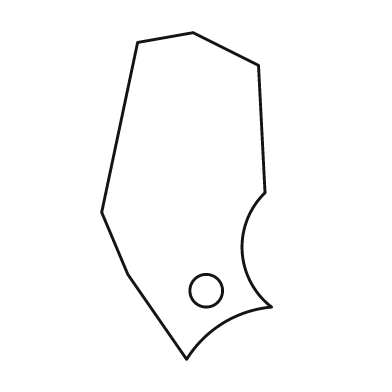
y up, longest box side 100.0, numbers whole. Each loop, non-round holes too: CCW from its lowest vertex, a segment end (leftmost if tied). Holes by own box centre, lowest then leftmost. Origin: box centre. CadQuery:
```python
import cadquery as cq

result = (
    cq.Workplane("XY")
    .moveTo(0.0, -50.0)
    .threePointArc((11.0, -39.0), (26.0, -34.0))
    .threePointArc((17.0, -17.0), (24.0, 1.0))
    .lineTo(22.0, 40.0)
    .lineTo(2.0, 50.0)
    .lineTo(-15.0, 47.0)
    .lineTo(-26.0, -5.0)
    .lineTo(-18.0, -24.0)
    .close()
    .moveTo(6.0, -29.0)
    .circle(5.0)
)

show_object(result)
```